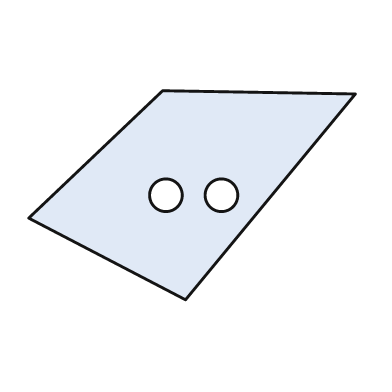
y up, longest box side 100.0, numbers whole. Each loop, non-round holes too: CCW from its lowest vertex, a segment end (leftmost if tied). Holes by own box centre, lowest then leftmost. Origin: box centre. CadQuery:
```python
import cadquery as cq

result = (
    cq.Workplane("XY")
    .moveTo(-2.0, -32.0)
    .lineTo(50.0, 31.0)
    .lineTo(-9.0, 32.0)
    .lineTo(-50.0, -7.0)
    .close()
    .moveTo(-8.0, 0.0)
    .circle(5.0)
    .moveTo(9.0, 0.0)
    .circle(5.0)
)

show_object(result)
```